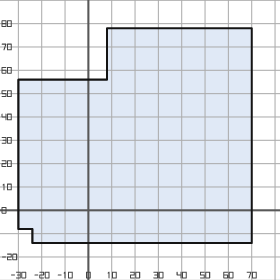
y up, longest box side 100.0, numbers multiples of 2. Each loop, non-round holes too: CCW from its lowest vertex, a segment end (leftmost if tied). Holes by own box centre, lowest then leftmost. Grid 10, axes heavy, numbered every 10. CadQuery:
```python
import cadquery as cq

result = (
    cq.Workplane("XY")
    .moveTo(-24.0, -14.0)
    .lineTo(70.0, -14.0)
    .lineTo(70.0, 78.0)
    .lineTo(8.0, 78.0)
    .lineTo(8.0, 56.0)
    .lineTo(-30.0, 56.0)
    .lineTo(-30.0, -8.0)
    .lineTo(-24.0, -8.0)
    .close()
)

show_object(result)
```